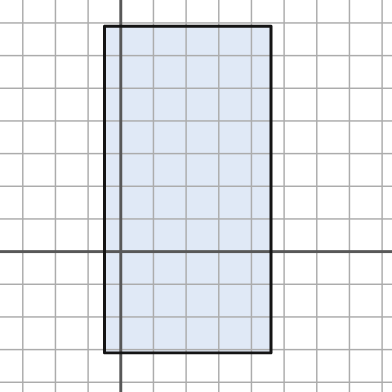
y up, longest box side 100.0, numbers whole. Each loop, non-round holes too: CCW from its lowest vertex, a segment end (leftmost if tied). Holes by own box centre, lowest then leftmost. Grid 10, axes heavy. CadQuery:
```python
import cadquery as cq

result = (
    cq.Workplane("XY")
    .moveTo(-5.0, -31.0)
    .lineTo(46.0, -31.0)
    .lineTo(46.0, 69.0)
    .lineTo(-5.0, 69.0)
    .close()
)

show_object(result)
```